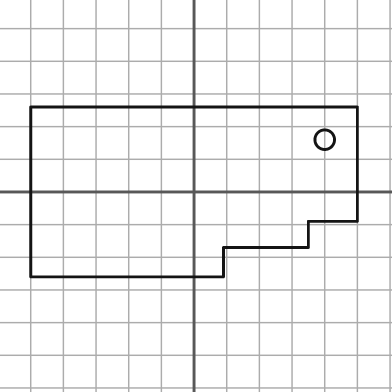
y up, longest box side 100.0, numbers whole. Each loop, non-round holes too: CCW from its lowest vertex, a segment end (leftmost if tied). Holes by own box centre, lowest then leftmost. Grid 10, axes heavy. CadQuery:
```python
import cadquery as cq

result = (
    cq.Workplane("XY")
    .moveTo(-50.0, -26.0)
    .lineTo(9.0, -26.0)
    .lineTo(9.0, -17.0)
    .lineTo(35.0, -17.0)
    .lineTo(35.0, -9.0)
    .lineTo(50.0, -9.0)
    .lineTo(50.0, 26.0)
    .lineTo(-50.0, 26.0)
    .close()
    .moveTo(40.0, 16.0)
    .circle(3.0)
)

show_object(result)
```